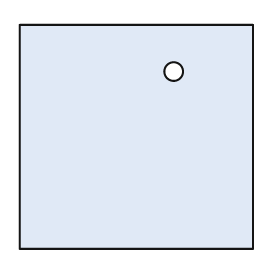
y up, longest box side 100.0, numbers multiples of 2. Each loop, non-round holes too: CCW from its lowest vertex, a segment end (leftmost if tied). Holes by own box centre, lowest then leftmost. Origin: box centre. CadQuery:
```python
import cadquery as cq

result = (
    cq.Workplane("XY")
    .moveTo(-50.0, -48.0)
    .lineTo(50.0, -48.0)
    .lineTo(50.0, 48.0)
    .lineTo(-50.0, 48.0)
    .close()
    .moveTo(16.0, 28.0)
    .circle(4.0)
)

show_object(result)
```